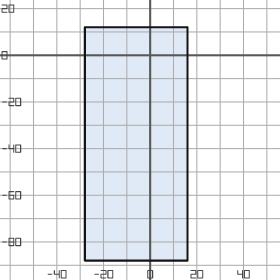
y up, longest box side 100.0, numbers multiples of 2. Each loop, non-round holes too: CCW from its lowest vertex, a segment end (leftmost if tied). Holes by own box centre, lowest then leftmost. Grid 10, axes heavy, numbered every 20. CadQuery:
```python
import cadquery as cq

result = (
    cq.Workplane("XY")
    .moveTo(-28.0, -88.0)
    .lineTo(16.0, -88.0)
    .lineTo(16.0, 12.0)
    .lineTo(-28.0, 12.0)
    .close()
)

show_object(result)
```